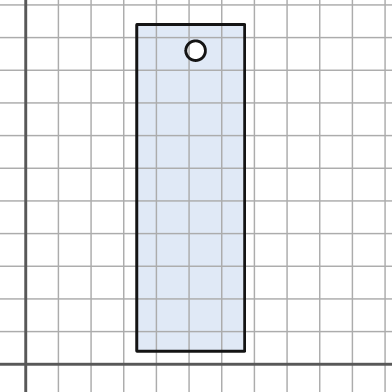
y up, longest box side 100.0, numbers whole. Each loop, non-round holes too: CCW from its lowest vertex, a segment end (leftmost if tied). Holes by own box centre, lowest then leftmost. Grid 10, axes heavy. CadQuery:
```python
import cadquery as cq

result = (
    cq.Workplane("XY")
    .moveTo(34.0, 4.0)
    .lineTo(67.0, 4.0)
    .lineTo(67.0, 104.0)
    .lineTo(34.0, 104.0)
    .close()
    .moveTo(52.0, 96.0)
    .circle(3.0)
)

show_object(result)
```